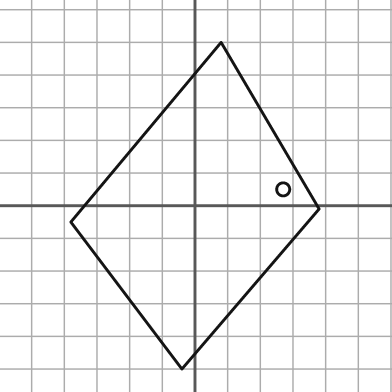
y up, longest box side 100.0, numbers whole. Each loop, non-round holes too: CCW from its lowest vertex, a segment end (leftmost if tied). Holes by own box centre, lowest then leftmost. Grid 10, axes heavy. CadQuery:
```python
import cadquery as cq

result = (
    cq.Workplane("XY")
    .moveTo(-4.0, -50.0)
    .lineTo(38.0, -1.0)
    .lineTo(8.0, 50.0)
    .lineTo(-38.0, -5.0)
    .close()
    .moveTo(27.0, 5.0)
    .circle(2.0)
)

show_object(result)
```